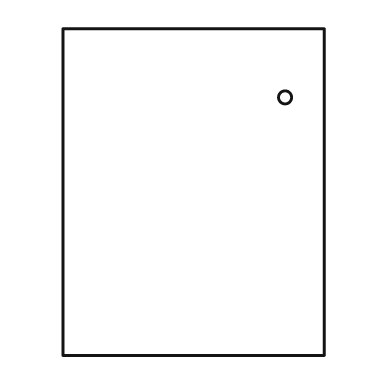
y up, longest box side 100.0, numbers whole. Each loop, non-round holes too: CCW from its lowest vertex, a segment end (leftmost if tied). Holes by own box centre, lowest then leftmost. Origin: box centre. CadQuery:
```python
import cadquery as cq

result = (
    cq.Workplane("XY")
    .moveTo(-40.0, -50.0)
    .lineTo(40.0, -50.0)
    .lineTo(40.0, 50.0)
    .lineTo(-40.0, 50.0)
    .close()
    .moveTo(28.0, 29.0)
    .circle(2.0)
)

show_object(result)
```